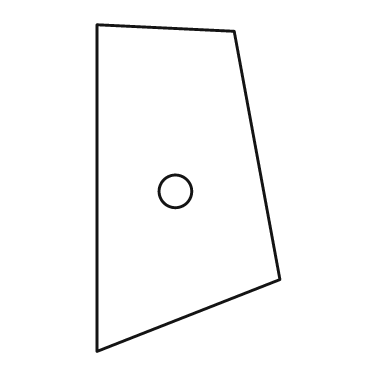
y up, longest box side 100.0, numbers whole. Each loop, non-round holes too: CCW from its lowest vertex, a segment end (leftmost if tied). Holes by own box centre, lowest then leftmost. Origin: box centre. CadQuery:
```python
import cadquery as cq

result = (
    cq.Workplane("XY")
    .moveTo(-28.0, -50.0)
    .lineTo(28.0, -28.0)
    .lineTo(14.0, 48.0)
    .lineTo(-28.0, 50.0)
    .close()
    .moveTo(-4.0, -1.0)
    .circle(5.0)
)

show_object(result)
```